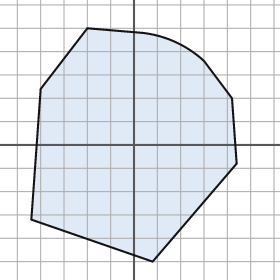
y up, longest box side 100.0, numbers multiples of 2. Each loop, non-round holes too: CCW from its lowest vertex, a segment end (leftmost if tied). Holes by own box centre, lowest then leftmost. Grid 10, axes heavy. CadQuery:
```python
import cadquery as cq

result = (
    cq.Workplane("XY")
    .moveTo(8.0, -50.0)
    .lineTo(44.0, -8.0)
    .lineTo(42.0, 20.0)
    .lineTo(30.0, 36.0)
    .threePointArc((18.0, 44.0), (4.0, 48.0))
    .lineTo(-20.0, 50.0)
    .lineTo(-40.0, 24.0)
    .lineTo(-44.0, -32.0)
    .close()
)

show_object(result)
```